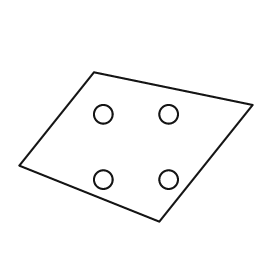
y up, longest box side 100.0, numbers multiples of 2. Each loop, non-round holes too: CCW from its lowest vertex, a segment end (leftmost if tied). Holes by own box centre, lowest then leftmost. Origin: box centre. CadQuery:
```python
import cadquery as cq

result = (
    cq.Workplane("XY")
    .moveTo(10.0, -32.0)
    .lineTo(50.0, 18.0)
    .lineTo(-18.0, 32.0)
    .lineTo(-50.0, -8.0)
    .close()
    .moveTo(-14.0, -14.0)
    .circle(4.0)
    .moveTo(14.0, -14.0)
    .circle(4.0)
    .moveTo(-14.0, 14.0)
    .circle(4.0)
    .moveTo(14.0, 14.0)
    .circle(4.0)
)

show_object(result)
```